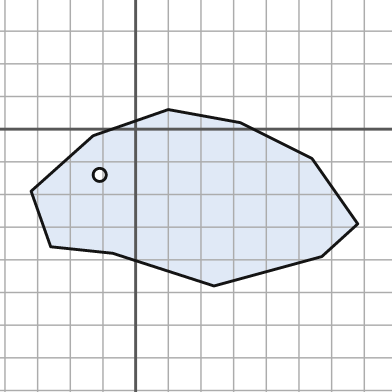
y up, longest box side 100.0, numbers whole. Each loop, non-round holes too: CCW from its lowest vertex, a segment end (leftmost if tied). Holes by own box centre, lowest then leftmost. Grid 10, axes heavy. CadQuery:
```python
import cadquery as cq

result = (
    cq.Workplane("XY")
    .moveTo(24.0, -48.0)
    .lineTo(57.0, -39.0)
    .lineTo(68.0, -29.0)
    .lineTo(54.0, -9.0)
    .lineTo(32.0, 2.0)
    .lineTo(10.0, 6.0)
    .lineTo(-13.0, -2.0)
    .lineTo(-32.0, -19.0)
    .lineTo(-26.0, -36.0)
    .lineTo(-7.0, -38.0)
    .close()
    .moveTo(-11.0, -14.0)
    .circle(2.0)
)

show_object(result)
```